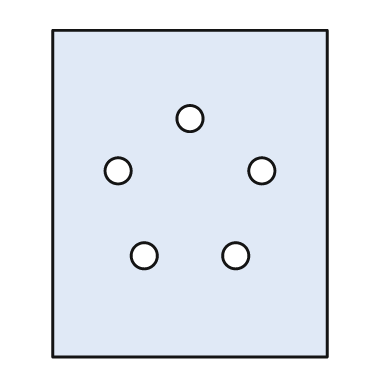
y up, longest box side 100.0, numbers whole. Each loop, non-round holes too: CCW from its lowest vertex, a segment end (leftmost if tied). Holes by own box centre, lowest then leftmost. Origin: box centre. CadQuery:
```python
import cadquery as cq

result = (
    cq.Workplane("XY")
    .moveTo(-42.0, -50.0)
    .lineTo(42.0, -50.0)
    .lineTo(42.0, 50.0)
    .lineTo(-42.0, 50.0)
    .close()
    .moveTo(-14.0, -19.0)
    .circle(4.0)
    .moveTo(14.0, -19.0)
    .circle(4.0)
    .moveTo(-22.0, 7.0)
    .circle(4.0)
    .moveTo(22.0, 7.0)
    .circle(4.0)
    .moveTo(0.0, 23.0)
    .circle(4.0)
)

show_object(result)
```